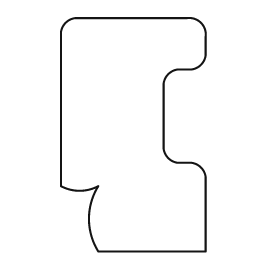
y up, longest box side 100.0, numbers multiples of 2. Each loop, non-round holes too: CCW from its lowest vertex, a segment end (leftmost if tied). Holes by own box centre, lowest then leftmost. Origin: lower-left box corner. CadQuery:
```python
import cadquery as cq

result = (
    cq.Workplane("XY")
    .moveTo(16.0, 0.0)
    .lineTo(62.0, 0.0)
    .lineTo(62.0, 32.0)
    .threePointArc((60.0, 36.0), (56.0, 38.0))
    .lineTo(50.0, 38.0)
    .threePointArc((46.0, 40.0), (44.0, 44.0))
    .lineTo(44.0, 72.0)
    .threePointArc((46.0, 76.0), (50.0, 78.0))
    .lineTo(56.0, 78.0)
    .threePointArc((60.0, 80.0), (62.0, 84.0))
    .lineTo(62.0, 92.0)
    .threePointArc((60.0, 98.0), (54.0, 100.0))
    .lineTo(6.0, 100.0)
    .threePointArc((2.0, 98.0), (0.0, 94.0))
    .lineTo(0.0, 28.0)
    .threePointArc((8.0, 26.0), (16.0, 28.0))
    .threePointArc((12.0, 14.0), (16.0, 0.0))
    .close()
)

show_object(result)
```